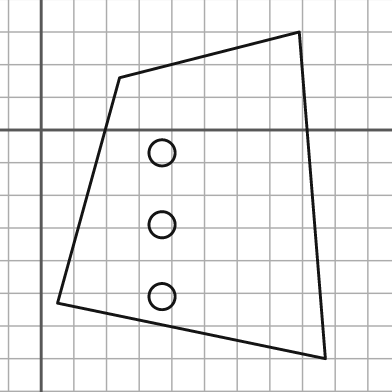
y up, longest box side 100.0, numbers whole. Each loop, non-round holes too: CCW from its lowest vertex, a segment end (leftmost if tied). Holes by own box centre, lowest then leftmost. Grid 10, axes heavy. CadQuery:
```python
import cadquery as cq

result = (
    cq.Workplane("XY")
    .moveTo(87.0, -70.0)
    .lineTo(79.0, 30.0)
    .lineTo(24.0, 16.0)
    .lineTo(5.0, -53.0)
    .close()
    .moveTo(37.0, -51.0)
    .circle(4.0)
    .moveTo(37.0, -29.0)
    .circle(4.0)
    .moveTo(37.0, -7.0)
    .circle(4.0)
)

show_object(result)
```